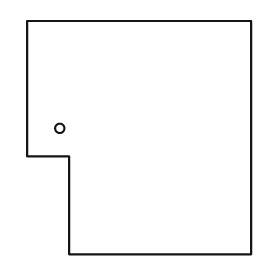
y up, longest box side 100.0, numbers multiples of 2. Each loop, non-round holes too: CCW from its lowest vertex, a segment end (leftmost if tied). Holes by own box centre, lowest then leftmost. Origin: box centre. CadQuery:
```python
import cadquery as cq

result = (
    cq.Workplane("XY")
    .moveTo(-30.0, -50.0)
    .lineTo(48.0, -50.0)
    .lineTo(48.0, 50.0)
    .lineTo(-48.0, 50.0)
    .lineTo(-48.0, -8.0)
    .lineTo(-30.0, -8.0)
    .close()
    .moveTo(-34.0, 4.0)
    .circle(2.0)
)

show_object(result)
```